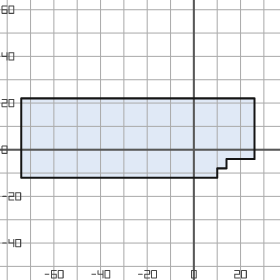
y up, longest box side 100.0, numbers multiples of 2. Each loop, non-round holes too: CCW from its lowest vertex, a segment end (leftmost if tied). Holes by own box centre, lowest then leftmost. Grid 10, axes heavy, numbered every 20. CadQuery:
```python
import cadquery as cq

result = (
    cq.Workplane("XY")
    .moveTo(-74.0, -12.0)
    .lineTo(10.0, -12.0)
    .lineTo(10.0, -8.0)
    .lineTo(14.0, -8.0)
    .lineTo(14.0, -4.0)
    .lineTo(26.0, -4.0)
    .lineTo(26.0, 22.0)
    .lineTo(-74.0, 22.0)
    .close()
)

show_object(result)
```